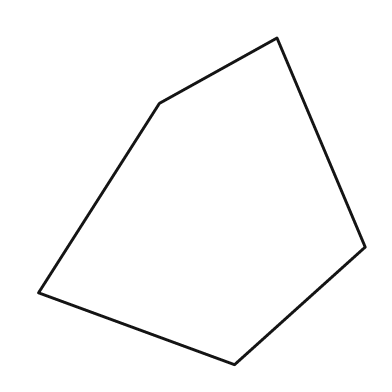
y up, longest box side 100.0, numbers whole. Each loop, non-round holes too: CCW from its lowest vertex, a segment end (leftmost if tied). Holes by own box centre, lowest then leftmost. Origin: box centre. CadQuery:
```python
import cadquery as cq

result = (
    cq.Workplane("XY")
    .moveTo(10.0, -50.0)
    .lineTo(50.0, -14.0)
    .lineTo(23.0, 50.0)
    .lineTo(-13.0, 30.0)
    .lineTo(-50.0, -28.0)
    .close()
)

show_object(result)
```